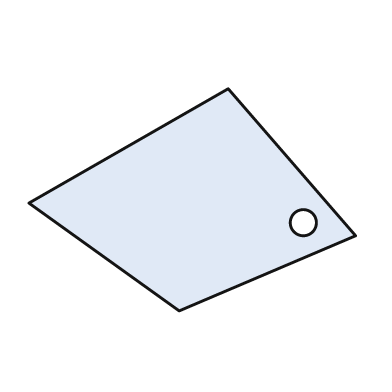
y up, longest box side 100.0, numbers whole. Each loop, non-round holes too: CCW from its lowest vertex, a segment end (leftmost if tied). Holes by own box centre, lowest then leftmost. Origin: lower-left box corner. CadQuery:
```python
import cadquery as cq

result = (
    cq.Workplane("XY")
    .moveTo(46.0, 0.0)
    .lineTo(100.0, 23.0)
    .lineTo(61.0, 68.0)
    .lineTo(0.0, 33.0)
    .close()
    .moveTo(84.0, 27.0)
    .circle(4.0)
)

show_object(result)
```